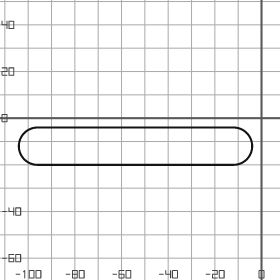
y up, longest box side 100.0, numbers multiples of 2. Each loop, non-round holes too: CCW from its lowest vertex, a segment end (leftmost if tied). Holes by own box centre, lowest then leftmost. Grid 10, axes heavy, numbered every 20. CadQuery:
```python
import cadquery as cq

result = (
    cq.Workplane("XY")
    .moveTo(-96.0, -20.0)
    .lineTo(-12.0, -20.0)
    .threePointArc((-4.0, -12.0), (-12.0, -4.0))
    .lineTo(-96.0, -4.0)
    .threePointArc((-104.0, -12.0), (-96.0, -20.0))
    .close()
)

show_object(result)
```